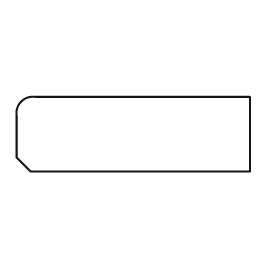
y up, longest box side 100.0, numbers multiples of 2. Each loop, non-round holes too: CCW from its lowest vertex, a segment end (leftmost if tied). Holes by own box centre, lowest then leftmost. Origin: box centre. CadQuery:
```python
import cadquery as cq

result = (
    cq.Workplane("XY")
    .moveTo(-44.0, -16.0)
    .lineTo(50.0, -16.0)
    .lineTo(50.0, 16.0)
    .lineTo(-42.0, 16.0)
    .threePointArc((-48.0, 14.0), (-50.0, 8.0))
    .lineTo(-50.0, -10.0)
    .close()
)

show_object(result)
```